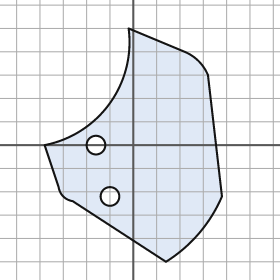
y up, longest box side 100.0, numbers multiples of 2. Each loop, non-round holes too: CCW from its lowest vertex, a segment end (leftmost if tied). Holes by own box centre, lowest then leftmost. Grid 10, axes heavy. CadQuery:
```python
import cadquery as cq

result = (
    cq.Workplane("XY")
    .moveTo(14.0, -50.0)
    .threePointArc((28.0, -38.0), (38.0, -22.0))
    .lineTo(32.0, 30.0)
    .threePointArc((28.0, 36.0), (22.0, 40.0))
    .lineTo(-2.0, 50.0)
    .threePointArc((-10.0, 18.0), (-38.0, 0.0))
    .lineTo(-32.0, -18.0)
    .threePointArc((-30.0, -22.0), (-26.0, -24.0))
    .close()
    .moveTo(-10.0, -22.0)
    .circle(4.0)
    .moveTo(-16.0, 0.0)
    .circle(4.0)
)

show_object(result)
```